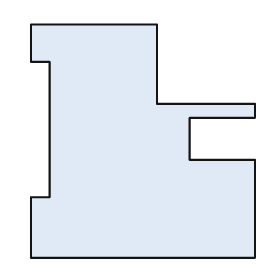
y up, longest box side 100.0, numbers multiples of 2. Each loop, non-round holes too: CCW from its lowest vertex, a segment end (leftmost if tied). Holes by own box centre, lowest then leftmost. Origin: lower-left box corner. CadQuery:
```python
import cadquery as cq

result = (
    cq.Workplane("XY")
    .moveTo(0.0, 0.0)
    .lineTo(96.0, 0.0)
    .lineTo(96.0, 42.0)
    .lineTo(68.0, 42.0)
    .lineTo(68.0, 60.0)
    .lineTo(96.0, 60.0)
    .lineTo(96.0, 66.0)
    .lineTo(54.0, 66.0)
    .lineTo(54.0, 100.0)
    .lineTo(0.0, 100.0)
    .lineTo(0.0, 84.0)
    .lineTo(8.0, 84.0)
    .lineTo(8.0, 26.0)
    .lineTo(0.0, 26.0)
    .close()
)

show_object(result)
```